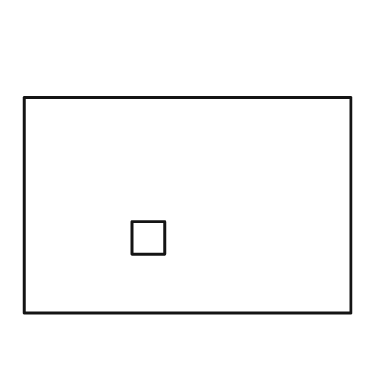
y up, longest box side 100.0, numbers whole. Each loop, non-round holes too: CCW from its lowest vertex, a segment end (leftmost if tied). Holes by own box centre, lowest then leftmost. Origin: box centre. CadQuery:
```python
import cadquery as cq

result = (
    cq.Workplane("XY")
    .moveTo(-50.0, -33.0)
    .lineTo(50.0, -33.0)
    .lineTo(50.0, 33.0)
    .lineTo(-50.0, 33.0)
    .close()
    .moveTo(-17.0, -15.0)
    .lineTo(-7.0, -15.0)
    .lineTo(-7.0, -5.0)
    .lineTo(-17.0, -5.0)
    .close()
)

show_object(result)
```